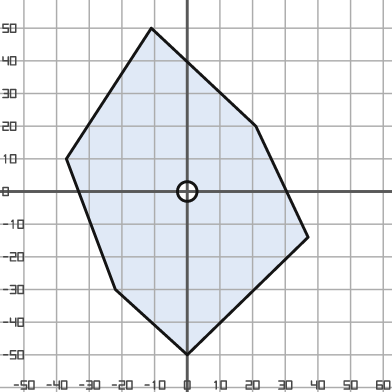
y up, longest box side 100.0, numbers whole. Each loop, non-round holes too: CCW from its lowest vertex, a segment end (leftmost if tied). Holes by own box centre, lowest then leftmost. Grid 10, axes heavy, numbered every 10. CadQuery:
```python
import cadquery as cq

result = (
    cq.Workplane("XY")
    .moveTo(0.0, -50.0)
    .lineTo(37.0, -14.0)
    .lineTo(21.0, 20.0)
    .lineTo(-11.0, 50.0)
    .lineTo(-37.0, 10.0)
    .lineTo(-22.0, -30.0)
    .close()
    .moveTo(0.0, 0.0)
    .circle(3.0)
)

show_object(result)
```